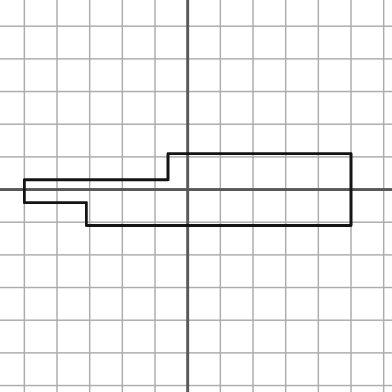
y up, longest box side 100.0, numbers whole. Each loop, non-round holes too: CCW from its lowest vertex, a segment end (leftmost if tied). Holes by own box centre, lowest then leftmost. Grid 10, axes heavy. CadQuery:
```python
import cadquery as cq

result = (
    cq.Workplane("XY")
    .moveTo(-31.0, -11.0)
    .lineTo(50.0, -11.0)
    .lineTo(50.0, 11.0)
    .lineTo(-6.0, 11.0)
    .lineTo(-6.0, 3.0)
    .lineTo(-50.0, 3.0)
    .lineTo(-50.0, -4.0)
    .lineTo(-31.0, -4.0)
    .close()
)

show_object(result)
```